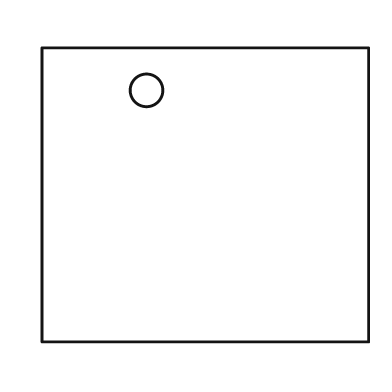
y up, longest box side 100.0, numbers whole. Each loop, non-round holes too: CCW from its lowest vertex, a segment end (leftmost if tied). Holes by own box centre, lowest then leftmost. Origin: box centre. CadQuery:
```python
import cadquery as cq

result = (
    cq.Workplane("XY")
    .moveTo(-50.0, -45.0)
    .lineTo(50.0, -45.0)
    .lineTo(50.0, 45.0)
    .lineTo(-50.0, 45.0)
    .close()
    .moveTo(-18.0, 32.0)
    .circle(5.0)
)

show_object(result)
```